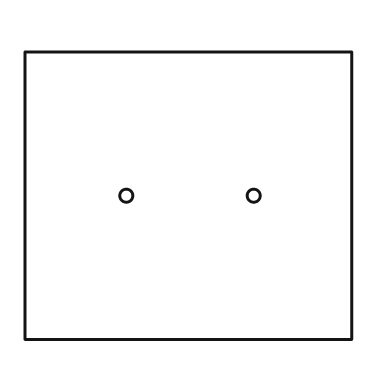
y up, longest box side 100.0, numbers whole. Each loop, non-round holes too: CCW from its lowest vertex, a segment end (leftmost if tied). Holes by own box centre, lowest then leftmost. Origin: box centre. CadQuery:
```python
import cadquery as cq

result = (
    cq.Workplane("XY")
    .moveTo(-50.0, -44.0)
    .lineTo(50.0, -44.0)
    .lineTo(50.0, 44.0)
    .lineTo(-50.0, 44.0)
    .close()
    .moveTo(-19.0, 0.0)
    .circle(2.0)
    .moveTo(20.0, 0.0)
    .circle(2.0)
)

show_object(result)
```